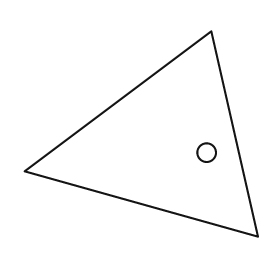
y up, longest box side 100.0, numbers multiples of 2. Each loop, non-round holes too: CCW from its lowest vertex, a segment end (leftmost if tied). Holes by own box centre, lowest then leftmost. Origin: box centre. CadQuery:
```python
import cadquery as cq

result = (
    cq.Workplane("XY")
    .moveTo(50.0, -44.0)
    .lineTo(30.0, 44.0)
    .lineTo(-50.0, -16.0)
    .close()
    .moveTo(28.0, -8.0)
    .circle(4.0)
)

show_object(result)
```